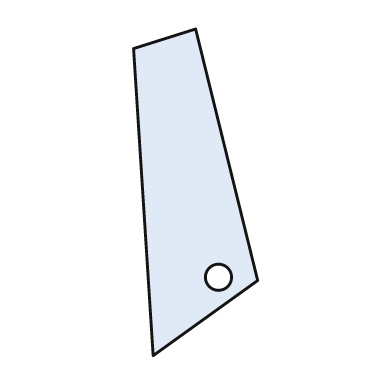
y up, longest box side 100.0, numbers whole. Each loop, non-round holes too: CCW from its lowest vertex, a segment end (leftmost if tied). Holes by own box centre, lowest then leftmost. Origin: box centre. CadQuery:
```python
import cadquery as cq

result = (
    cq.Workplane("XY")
    .moveTo(-13.0, -50.0)
    .lineTo(19.0, -27.0)
    .lineTo(0.0, 50.0)
    .lineTo(-19.0, 44.0)
    .close()
    .moveTo(7.0, -26.0)
    .circle(4.0)
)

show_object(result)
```